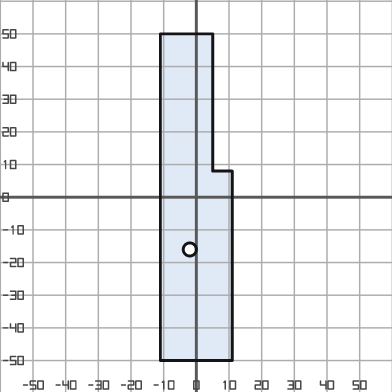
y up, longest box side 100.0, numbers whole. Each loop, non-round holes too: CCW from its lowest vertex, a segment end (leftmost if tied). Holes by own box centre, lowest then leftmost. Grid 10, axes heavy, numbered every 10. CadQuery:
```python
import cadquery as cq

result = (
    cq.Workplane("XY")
    .moveTo(-11.0, -50.0)
    .lineTo(11.0, -50.0)
    .lineTo(11.0, 8.0)
    .lineTo(5.0, 8.0)
    .lineTo(5.0, 50.0)
    .lineTo(-11.0, 50.0)
    .close()
    .moveTo(-2.0, -16.0)
    .circle(2.0)
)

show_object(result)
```